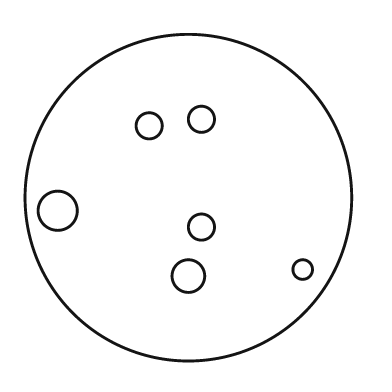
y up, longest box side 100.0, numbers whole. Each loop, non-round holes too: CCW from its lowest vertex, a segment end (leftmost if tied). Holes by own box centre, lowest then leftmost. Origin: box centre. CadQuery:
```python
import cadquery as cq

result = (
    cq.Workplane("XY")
    .moveTo(0.0, 0.0)
    .circle(50.0)
    .moveTo(0.0, -24.0)
    .circle(5.0)
    .moveTo(35.0, -22.0)
    .circle(3.0)
    .moveTo(4.0, -9.0)
    .circle(4.0)
    .moveTo(-40.0, -4.0)
    .circle(6.0)
    .moveTo(-12.0, 22.0)
    .circle(4.0)
    .moveTo(4.0, 24.0)
    .circle(4.0)
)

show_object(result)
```